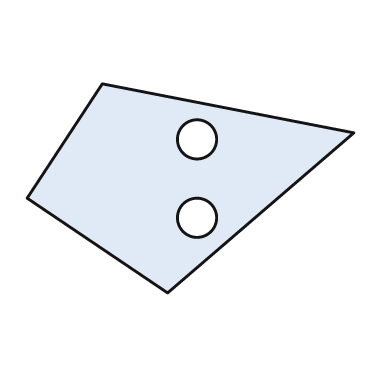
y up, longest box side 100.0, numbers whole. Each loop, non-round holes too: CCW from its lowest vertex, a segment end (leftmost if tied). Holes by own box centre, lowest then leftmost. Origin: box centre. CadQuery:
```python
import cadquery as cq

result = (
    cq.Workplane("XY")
    .moveTo(-7.0, -32.0)
    .lineTo(50.0, 17.0)
    .lineTo(-27.0, 32.0)
    .lineTo(-50.0, -3.0)
    .close()
    .moveTo(2.0, -9.0)
    .circle(6.0)
    .moveTo(2.0, 15.0)
    .circle(6.0)
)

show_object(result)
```